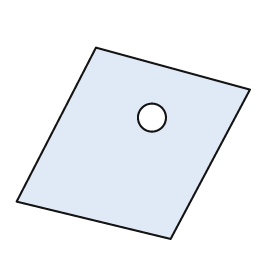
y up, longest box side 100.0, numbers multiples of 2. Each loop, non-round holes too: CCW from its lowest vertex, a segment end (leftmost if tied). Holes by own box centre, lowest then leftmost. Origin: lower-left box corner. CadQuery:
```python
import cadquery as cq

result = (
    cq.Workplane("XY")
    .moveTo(66.0, 0.0)
    .lineTo(100.0, 64.0)
    .lineTo(34.0, 82.0)
    .lineTo(0.0, 16.0)
    .close()
    .moveTo(58.0, 52.0)
    .circle(6.0)
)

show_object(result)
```